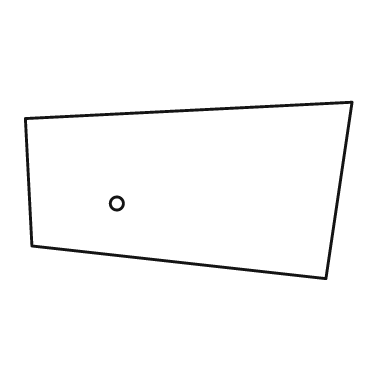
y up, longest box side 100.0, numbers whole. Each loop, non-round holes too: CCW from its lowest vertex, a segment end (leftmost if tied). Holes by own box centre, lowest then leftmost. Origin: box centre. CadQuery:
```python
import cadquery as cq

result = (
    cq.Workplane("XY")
    .moveTo(42.0, -27.0)
    .lineTo(50.0, 27.0)
    .lineTo(-50.0, 22.0)
    .lineTo(-48.0, -17.0)
    .close()
    .moveTo(-22.0, -4.0)
    .circle(2.0)
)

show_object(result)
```